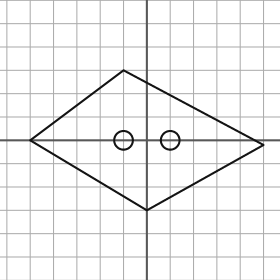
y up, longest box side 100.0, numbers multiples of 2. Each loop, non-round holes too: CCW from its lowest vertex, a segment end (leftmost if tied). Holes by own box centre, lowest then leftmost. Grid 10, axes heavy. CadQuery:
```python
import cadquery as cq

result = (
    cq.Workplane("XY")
    .moveTo(0.0, -30.0)
    .lineTo(50.0, -2.0)
    .lineTo(-10.0, 30.0)
    .lineTo(-50.0, 0.0)
    .close()
    .moveTo(-10.0, 0.0)
    .circle(4.0)
    .moveTo(10.0, 0.0)
    .circle(4.0)
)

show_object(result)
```